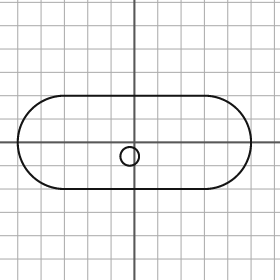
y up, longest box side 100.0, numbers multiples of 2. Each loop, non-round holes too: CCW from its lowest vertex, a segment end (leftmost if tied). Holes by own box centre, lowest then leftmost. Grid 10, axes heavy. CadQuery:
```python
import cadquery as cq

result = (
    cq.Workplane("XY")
    .moveTo(-30.0, -20.0)
    .lineTo(30.0, -20.0)
    .threePointArc((50.0, 0.0), (30.0, 20.0))
    .lineTo(-30.0, 20.0)
    .threePointArc((-50.0, 0.0), (-30.0, -20.0))
    .close()
    .moveTo(-2.0, -6.0)
    .circle(4.0)
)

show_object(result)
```